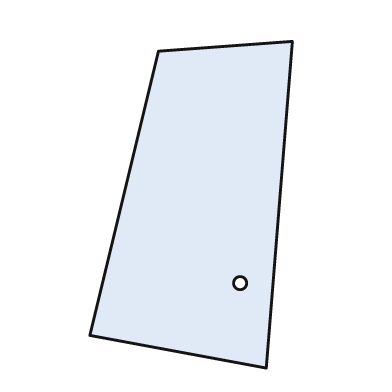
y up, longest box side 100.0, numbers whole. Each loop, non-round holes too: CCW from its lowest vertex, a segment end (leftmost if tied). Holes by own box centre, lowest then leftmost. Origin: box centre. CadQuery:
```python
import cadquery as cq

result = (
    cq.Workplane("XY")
    .moveTo(23.0, -50.0)
    .lineTo(31.0, 50.0)
    .lineTo(-10.0, 47.0)
    .lineTo(-31.0, -40.0)
    .close()
    .moveTo(15.0, -24.0)
    .circle(2.0)
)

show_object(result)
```